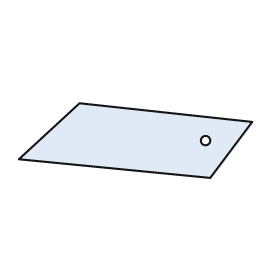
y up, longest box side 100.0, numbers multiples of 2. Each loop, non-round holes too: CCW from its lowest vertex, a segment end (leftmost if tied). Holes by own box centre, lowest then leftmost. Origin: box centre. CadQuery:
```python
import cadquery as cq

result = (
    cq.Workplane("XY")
    .moveTo(32.0, -16.0)
    .lineTo(50.0, 8.0)
    .lineTo(-24.0, 16.0)
    .lineTo(-50.0, -8.0)
    .close()
    .moveTo(30.0, 0.0)
    .circle(2.0)
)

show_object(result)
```